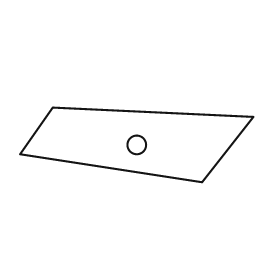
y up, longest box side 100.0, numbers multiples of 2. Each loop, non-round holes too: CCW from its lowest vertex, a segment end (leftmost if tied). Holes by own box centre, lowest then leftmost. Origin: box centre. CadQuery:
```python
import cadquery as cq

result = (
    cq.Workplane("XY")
    .moveTo(28.0, -16.0)
    .lineTo(50.0, 12.0)
    .lineTo(-36.0, 16.0)
    .lineTo(-50.0, -4.0)
    .close()
    .moveTo(0.0, 0.0)
    .circle(4.0)
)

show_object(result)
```